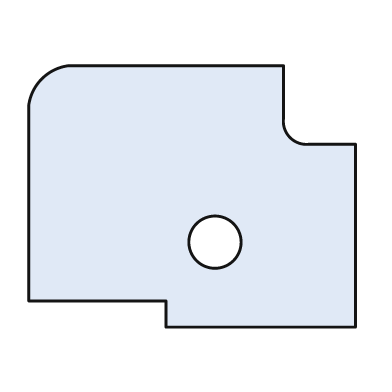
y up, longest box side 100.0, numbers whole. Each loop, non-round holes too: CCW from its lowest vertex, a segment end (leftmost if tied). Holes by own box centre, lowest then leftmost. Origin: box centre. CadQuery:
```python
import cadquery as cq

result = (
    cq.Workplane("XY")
    .moveTo(-8.0, -40.0)
    .lineTo(50.0, -40.0)
    .lineTo(50.0, 16.0)
    .lineTo(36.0, 16.0)
    .threePointArc((30.0, 18.0), (28.0, 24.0))
    .lineTo(28.0, 40.0)
    .lineTo(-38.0, 40.0)
    .threePointArc((-46.0, 36.0), (-50.0, 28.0))
    .lineTo(-50.0, -32.0)
    .lineTo(-8.0, -32.0)
    .close()
    .moveTo(7.0, -14.0)
    .circle(8.0)
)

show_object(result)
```